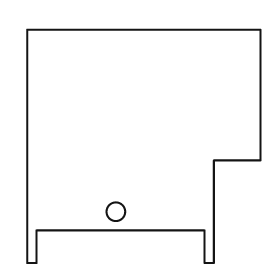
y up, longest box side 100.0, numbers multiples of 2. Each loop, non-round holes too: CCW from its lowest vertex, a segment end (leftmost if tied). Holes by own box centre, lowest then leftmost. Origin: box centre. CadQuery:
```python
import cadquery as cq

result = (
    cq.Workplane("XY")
    .moveTo(-50.0, -50.0)
    .lineTo(-46.0, -50.0)
    .lineTo(-46.0, -36.0)
    .lineTo(26.0, -36.0)
    .lineTo(26.0, -50.0)
    .lineTo(30.0, -50.0)
    .lineTo(30.0, -6.0)
    .lineTo(50.0, -6.0)
    .lineTo(50.0, 50.0)
    .lineTo(-50.0, 50.0)
    .close()
    .moveTo(-12.0, -28.0)
    .circle(4.0)
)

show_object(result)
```